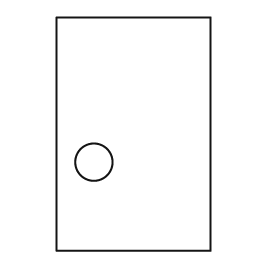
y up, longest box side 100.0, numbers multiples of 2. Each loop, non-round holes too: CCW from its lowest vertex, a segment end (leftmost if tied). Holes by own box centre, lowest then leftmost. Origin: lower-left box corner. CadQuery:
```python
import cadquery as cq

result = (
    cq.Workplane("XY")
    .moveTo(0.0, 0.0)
    .lineTo(66.0, 0.0)
    .lineTo(66.0, 100.0)
    .lineTo(0.0, 100.0)
    .close()
    .moveTo(16.0, 38.0)
    .circle(8.0)
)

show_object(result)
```